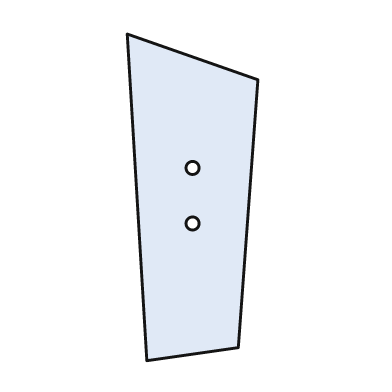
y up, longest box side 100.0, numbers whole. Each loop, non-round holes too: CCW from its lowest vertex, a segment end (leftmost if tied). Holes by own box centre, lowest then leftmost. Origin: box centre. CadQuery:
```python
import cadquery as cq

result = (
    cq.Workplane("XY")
    .moveTo(-14.0, -50.0)
    .lineTo(14.0, -46.0)
    .lineTo(20.0, 36.0)
    .lineTo(-20.0, 50.0)
    .close()
    .moveTo(0.0, -8.0)
    .circle(2.0)
    .moveTo(0.0, 9.0)
    .circle(2.0)
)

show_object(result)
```